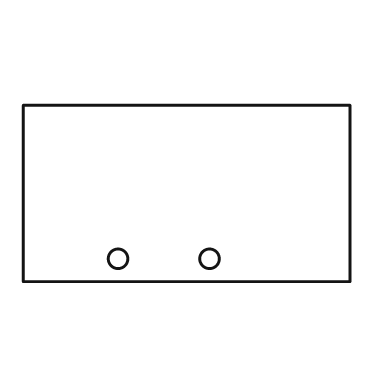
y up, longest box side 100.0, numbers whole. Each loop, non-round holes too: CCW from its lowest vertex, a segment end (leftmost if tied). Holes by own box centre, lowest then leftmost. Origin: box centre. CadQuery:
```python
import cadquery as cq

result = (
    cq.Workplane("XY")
    .moveTo(-50.0, -27.0)
    .lineTo(50.0, -27.0)
    .lineTo(50.0, 27.0)
    .lineTo(-50.0, 27.0)
    .close()
    .moveTo(-21.0, -20.0)
    .circle(3.0)
    .moveTo(7.0, -20.0)
    .circle(3.0)
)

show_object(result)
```